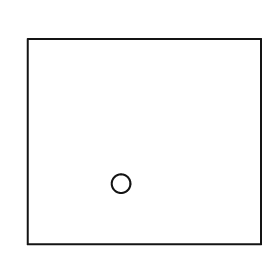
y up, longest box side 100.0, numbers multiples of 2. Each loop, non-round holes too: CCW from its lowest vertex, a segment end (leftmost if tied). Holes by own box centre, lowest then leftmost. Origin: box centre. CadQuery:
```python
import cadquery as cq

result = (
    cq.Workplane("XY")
    .moveTo(-50.0, -44.0)
    .lineTo(50.0, -44.0)
    .lineTo(50.0, 44.0)
    .lineTo(-50.0, 44.0)
    .close()
    .moveTo(-10.0, -18.0)
    .circle(4.0)
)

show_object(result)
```